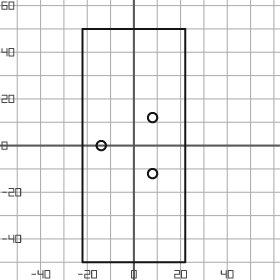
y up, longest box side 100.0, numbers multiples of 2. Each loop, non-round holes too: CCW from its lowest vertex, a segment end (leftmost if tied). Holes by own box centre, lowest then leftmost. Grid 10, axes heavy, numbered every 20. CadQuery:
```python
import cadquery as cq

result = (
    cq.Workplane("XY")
    .moveTo(-22.0, -50.0)
    .lineTo(22.0, -50.0)
    .lineTo(22.0, 50.0)
    .lineTo(-22.0, 50.0)
    .close()
    .moveTo(8.0, -12.0)
    .circle(2.0)
    .moveTo(-14.0, 0.0)
    .circle(2.0)
    .moveTo(8.0, 12.0)
    .circle(2.0)
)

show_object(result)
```